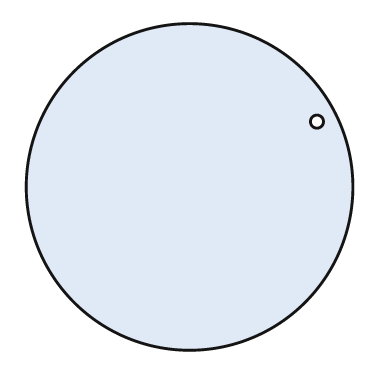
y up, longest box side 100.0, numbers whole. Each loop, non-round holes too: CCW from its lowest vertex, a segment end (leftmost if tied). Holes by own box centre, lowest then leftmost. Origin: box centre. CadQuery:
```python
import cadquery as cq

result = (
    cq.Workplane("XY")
    .moveTo(0.0, 0.0)
    .circle(50.0)
    .moveTo(39.0, 20.0)
    .circle(2.0)
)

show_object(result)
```